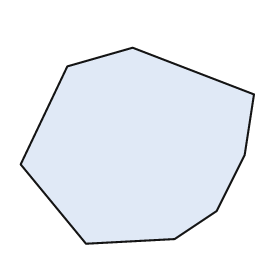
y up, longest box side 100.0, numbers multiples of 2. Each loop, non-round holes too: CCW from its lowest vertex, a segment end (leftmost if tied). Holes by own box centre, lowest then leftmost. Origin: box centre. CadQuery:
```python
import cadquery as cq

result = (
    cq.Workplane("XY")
    .moveTo(-22.0, -42.0)
    .lineTo(16.0, -40.0)
    .lineTo(34.0, -28.0)
    .lineTo(46.0, -4.0)
    .lineTo(50.0, 22.0)
    .lineTo(-2.0, 42.0)
    .lineTo(-30.0, 34.0)
    .lineTo(-50.0, -8.0)
    .close()
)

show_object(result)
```